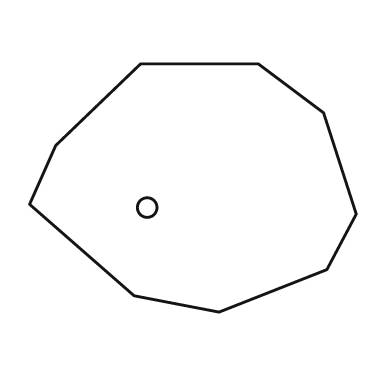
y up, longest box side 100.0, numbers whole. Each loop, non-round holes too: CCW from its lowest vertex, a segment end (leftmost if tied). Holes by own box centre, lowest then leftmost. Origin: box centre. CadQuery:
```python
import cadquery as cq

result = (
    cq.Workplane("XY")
    .moveTo(8.0, -38.0)
    .lineTo(41.0, -25.0)
    .lineTo(50.0, -8.0)
    .lineTo(40.0, 23.0)
    .lineTo(20.0, 38.0)
    .lineTo(-16.0, 38.0)
    .lineTo(-42.0, 13.0)
    .lineTo(-50.0, -5.0)
    .lineTo(-18.0, -33.0)
    .close()
    .moveTo(-14.0, -6.0)
    .circle(3.0)
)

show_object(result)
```